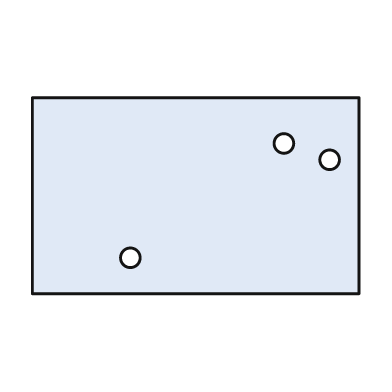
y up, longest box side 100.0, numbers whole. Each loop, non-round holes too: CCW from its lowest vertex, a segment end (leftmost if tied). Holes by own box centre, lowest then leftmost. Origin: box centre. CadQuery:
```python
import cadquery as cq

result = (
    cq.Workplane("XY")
    .moveTo(-50.0, -30.0)
    .lineTo(50.0, -30.0)
    .lineTo(50.0, 30.0)
    .lineTo(-50.0, 30.0)
    .close()
    .moveTo(-20.0, -19.0)
    .circle(3.0)
    .moveTo(41.0, 11.0)
    .circle(3.0)
    .moveTo(27.0, 16.0)
    .circle(3.0)
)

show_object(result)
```